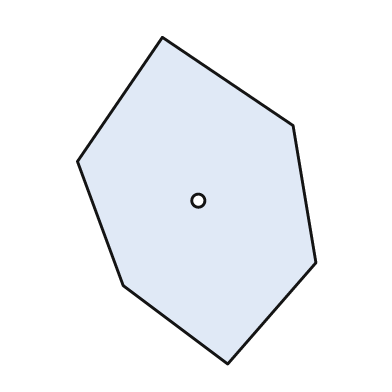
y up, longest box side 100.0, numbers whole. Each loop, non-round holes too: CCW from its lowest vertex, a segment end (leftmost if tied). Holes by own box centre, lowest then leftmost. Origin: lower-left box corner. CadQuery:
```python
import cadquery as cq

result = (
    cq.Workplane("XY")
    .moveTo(46.0, 0.0)
    .lineTo(73.0, 31.0)
    .lineTo(66.0, 73.0)
    .lineTo(26.0, 100.0)
    .lineTo(0.0, 62.0)
    .lineTo(14.0, 24.0)
    .close()
    .moveTo(37.0, 50.0)
    .circle(2.0)
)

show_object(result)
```